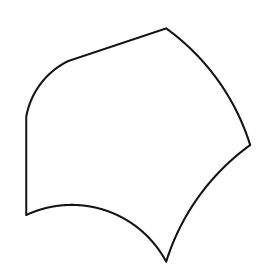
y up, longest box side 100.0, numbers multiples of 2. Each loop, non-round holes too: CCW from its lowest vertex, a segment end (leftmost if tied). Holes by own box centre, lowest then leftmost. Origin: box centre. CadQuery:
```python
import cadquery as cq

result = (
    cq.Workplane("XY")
    .moveTo(12.0, -50.0)
    .threePointArc((26.0, -22.0), (48.0, 0.0))
    .threePointArc((34.0, 28.0), (12.0, 50.0))
    .lineTo(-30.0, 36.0)
    .threePointArc((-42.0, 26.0), (-48.0, 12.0))
    .lineTo(-48.0, -30.0)
    .threePointArc((-14.0, -28.0), (12.0, -50.0))
    .close()
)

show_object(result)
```